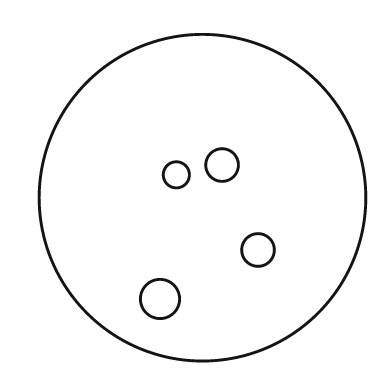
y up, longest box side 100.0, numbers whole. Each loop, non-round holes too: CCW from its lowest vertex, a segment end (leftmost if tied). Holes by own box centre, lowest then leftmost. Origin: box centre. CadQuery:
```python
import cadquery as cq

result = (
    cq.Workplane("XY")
    .moveTo(0.0, 0.0)
    .circle(50.0)
    .moveTo(-13.0, -31.0)
    .circle(6.0)
    .moveTo(17.0, -16.0)
    .circle(5.0)
    .moveTo(-8.0, 7.0)
    .circle(4.0)
    .moveTo(6.0, 10.0)
    .circle(5.0)
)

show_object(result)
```